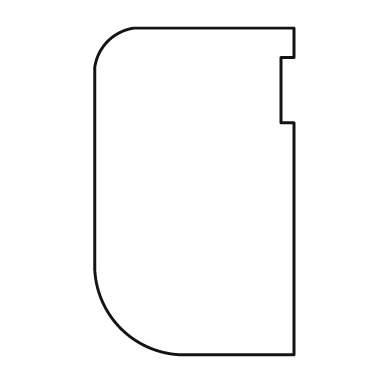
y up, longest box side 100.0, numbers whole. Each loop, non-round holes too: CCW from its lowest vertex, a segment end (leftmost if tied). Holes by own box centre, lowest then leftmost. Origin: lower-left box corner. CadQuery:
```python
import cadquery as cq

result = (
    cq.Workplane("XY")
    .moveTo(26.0, 0.0)
    .lineTo(61.0, 0.0)
    .lineTo(61.0, 71.0)
    .lineTo(57.0, 71.0)
    .lineTo(57.0, 91.0)
    .lineTo(61.0, 91.0)
    .lineTo(61.0, 100.0)
    .lineTo(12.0, 100.0)
    .threePointArc((4.0, 96.0), (0.0, 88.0))
    .lineTo(0.0, 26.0)
    .threePointArc((8.0, 8.0), (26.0, 0.0))
    .close()
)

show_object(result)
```